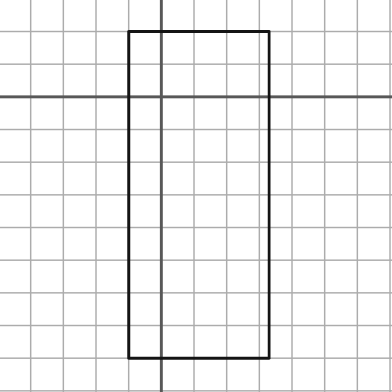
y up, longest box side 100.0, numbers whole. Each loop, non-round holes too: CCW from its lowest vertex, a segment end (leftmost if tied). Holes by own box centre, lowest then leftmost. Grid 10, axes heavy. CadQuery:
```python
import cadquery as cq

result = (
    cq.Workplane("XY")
    .moveTo(-10.0, -80.0)
    .lineTo(33.0, -80.0)
    .lineTo(33.0, 20.0)
    .lineTo(-10.0, 20.0)
    .close()
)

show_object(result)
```